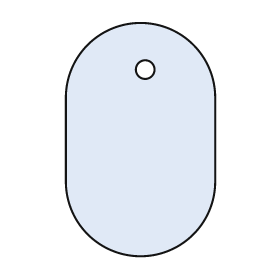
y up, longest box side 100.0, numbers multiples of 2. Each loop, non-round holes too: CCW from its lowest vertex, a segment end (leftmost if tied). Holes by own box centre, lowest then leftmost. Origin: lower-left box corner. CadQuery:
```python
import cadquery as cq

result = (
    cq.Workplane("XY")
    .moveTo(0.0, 32.0)
    .threePointArc((32.0, 0.0), (64.0, 32.0))
    .lineTo(64.0, 68.0)
    .threePointArc((32.0, 100.0), (0.0, 68.0))
    .close()
    .moveTo(34.0, 80.0)
    .circle(4.0)
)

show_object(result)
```